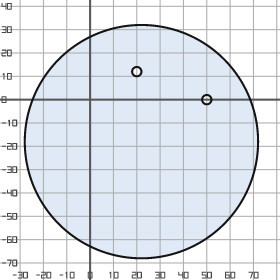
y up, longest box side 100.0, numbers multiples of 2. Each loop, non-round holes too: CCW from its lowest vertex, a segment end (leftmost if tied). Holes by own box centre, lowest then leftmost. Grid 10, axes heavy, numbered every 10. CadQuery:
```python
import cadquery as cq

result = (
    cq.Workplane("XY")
    .moveTo(22.0, -18.0)
    .circle(50.0)
    .moveTo(50.0, 0.0)
    .circle(2.0)
    .moveTo(20.0, 12.0)
    .circle(2.0)
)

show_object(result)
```